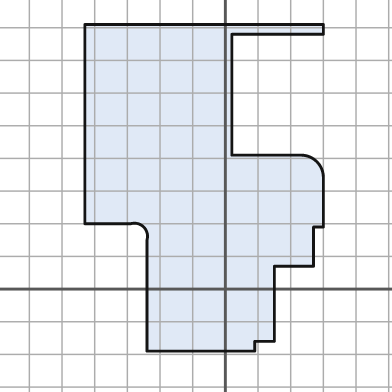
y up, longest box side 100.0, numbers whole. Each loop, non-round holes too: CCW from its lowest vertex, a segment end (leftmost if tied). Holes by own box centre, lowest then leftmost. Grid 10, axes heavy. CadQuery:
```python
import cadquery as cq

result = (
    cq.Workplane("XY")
    .moveTo(-24.0, -19.0)
    .lineTo(9.0, -19.0)
    .lineTo(9.0, -16.0)
    .lineTo(15.0, -16.0)
    .lineTo(15.0, 7.0)
    .lineTo(27.0, 7.0)
    .lineTo(27.0, 19.0)
    .lineTo(30.0, 19.0)
    .lineTo(30.0, 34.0)
    .threePointArc((28.0, 39.0), (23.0, 41.0))
    .lineTo(2.0, 41.0)
    .lineTo(2.0, 78.0)
    .lineTo(30.0, 78.0)
    .lineTo(30.0, 81.0)
    .lineTo(-43.0, 81.0)
    .lineTo(-43.0, 20.0)
    .lineTo(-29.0, 20.0)
    .threePointArc((-25.0, 19.0), (-24.0, 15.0))
    .close()
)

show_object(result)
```